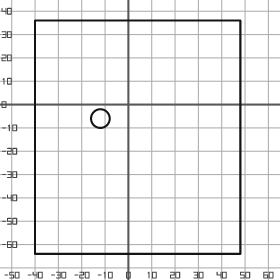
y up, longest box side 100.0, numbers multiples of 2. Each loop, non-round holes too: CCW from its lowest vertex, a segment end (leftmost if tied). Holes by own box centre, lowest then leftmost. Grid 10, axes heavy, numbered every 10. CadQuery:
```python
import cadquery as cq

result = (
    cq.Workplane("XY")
    .moveTo(-40.0, -64.0)
    .lineTo(48.0, -64.0)
    .lineTo(48.0, 36.0)
    .lineTo(-40.0, 36.0)
    .close()
    .moveTo(-12.0, -6.0)
    .circle(4.0)
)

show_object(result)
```